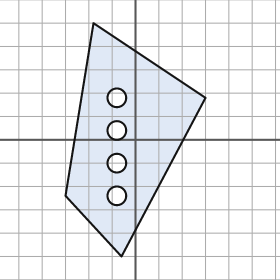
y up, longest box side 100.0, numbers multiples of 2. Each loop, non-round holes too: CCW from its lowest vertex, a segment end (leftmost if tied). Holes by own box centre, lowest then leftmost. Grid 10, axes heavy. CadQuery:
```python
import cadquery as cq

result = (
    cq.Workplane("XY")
    .moveTo(-6.0, -50.0)
    .lineTo(30.0, 18.0)
    .lineTo(-18.0, 50.0)
    .lineTo(-30.0, -24.0)
    .close()
    .moveTo(-8.0, -24.0)
    .circle(4.0)
    .moveTo(-8.0, -10.0)
    .circle(4.0)
    .moveTo(-8.0, 4.0)
    .circle(4.0)
    .moveTo(-8.0, 18.0)
    .circle(4.0)
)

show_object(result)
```